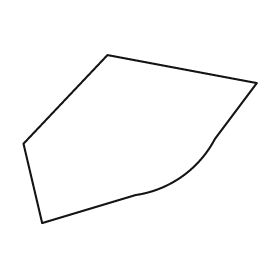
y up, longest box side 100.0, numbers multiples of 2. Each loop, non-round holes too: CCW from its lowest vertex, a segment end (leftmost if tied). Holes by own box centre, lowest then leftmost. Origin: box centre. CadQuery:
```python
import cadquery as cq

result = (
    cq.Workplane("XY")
    .moveTo(-42.0, -36.0)
    .lineTo(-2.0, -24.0)
    .threePointArc((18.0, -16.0), (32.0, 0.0))
    .lineTo(50.0, 24.0)
    .lineTo(-14.0, 36.0)
    .lineTo(-50.0, -2.0)
    .close()
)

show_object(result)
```